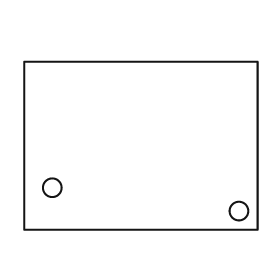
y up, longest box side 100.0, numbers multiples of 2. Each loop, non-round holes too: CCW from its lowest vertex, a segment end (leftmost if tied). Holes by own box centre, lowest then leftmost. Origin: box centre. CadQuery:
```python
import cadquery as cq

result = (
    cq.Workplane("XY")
    .moveTo(-50.0, -36.0)
    .lineTo(50.0, -36.0)
    .lineTo(50.0, 36.0)
    .lineTo(-50.0, 36.0)
    .close()
    .moveTo(42.0, -28.0)
    .circle(4.0)
    .moveTo(-38.0, -18.0)
    .circle(4.0)
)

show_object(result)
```